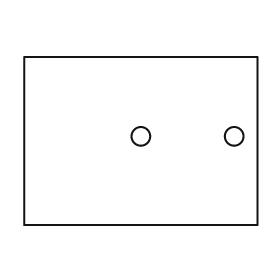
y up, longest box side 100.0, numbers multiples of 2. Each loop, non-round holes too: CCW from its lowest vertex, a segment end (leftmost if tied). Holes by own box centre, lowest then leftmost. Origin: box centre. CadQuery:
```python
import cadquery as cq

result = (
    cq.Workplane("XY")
    .moveTo(-50.0, -36.0)
    .lineTo(50.0, -36.0)
    .lineTo(50.0, 36.0)
    .lineTo(-50.0, 36.0)
    .close()
    .moveTo(0.0, 2.0)
    .circle(4.0)
    .moveTo(40.0, 2.0)
    .circle(4.0)
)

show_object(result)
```